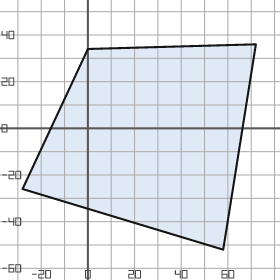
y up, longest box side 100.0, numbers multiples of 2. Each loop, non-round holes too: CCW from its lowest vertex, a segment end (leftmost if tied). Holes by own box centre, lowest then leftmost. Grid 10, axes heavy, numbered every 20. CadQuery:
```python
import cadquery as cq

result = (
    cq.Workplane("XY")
    .moveTo(58.0, -52.0)
    .lineTo(72.0, 36.0)
    .lineTo(0.0, 34.0)
    .lineTo(-28.0, -26.0)
    .close()
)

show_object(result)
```